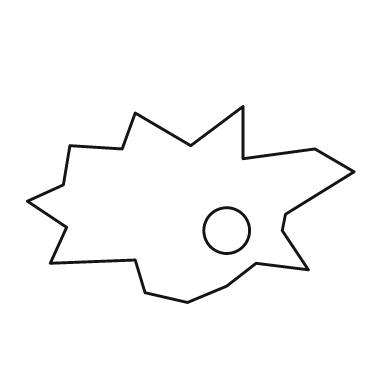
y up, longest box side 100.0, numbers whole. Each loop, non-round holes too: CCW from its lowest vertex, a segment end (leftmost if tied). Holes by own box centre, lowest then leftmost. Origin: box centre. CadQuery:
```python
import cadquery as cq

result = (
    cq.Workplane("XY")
    .moveTo(-1.0, -30.0)
    .lineTo(11.0, -25.0)
    .lineTo(20.0, -18.0)
    .lineTo(36.0, -20.0)
    .lineTo(28.0, -8.0)
    .lineTo(29.0, -3.0)
    .lineTo(50.0, 10.0)
    .lineTo(38.0, 17.0)
    .lineTo(16.0, 14.0)
    .lineTo(16.0, 30.0)
    .lineTo(0.0, 18.0)
    .lineTo(-17.0, 28.0)
    .lineTo(-21.0, 17.0)
    .lineTo(-37.0, 18.0)
    .lineTo(-39.0, 6.0)
    .lineTo(-50.0, 1.0)
    .lineTo(-38.0, -7.0)
    .lineTo(-43.0, -18.0)
    .lineTo(-17.0, -17.0)
    .lineTo(-14.0, -27.0)
    .close()
    .moveTo(11.0, -8.0)
    .circle(7.0)
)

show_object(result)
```